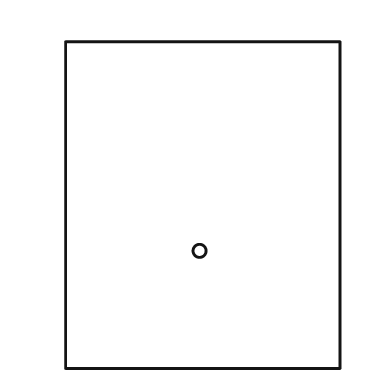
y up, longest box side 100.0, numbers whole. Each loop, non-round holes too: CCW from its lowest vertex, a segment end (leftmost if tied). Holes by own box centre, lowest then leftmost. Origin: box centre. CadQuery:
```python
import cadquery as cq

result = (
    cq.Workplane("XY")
    .moveTo(-42.0, -50.0)
    .lineTo(42.0, -50.0)
    .lineTo(42.0, 50.0)
    .lineTo(-42.0, 50.0)
    .close()
    .moveTo(-1.0, -14.0)
    .circle(2.0)
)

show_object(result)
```